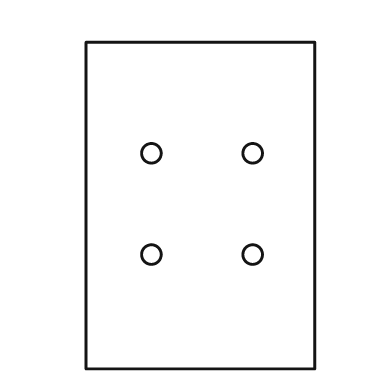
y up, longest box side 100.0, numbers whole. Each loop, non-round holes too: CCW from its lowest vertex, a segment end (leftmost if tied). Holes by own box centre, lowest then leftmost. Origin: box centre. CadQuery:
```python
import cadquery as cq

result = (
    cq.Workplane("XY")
    .moveTo(-35.0, -50.0)
    .lineTo(35.0, -50.0)
    .lineTo(35.0, 50.0)
    .lineTo(-35.0, 50.0)
    .close()
    .moveTo(-15.0, -15.0)
    .circle(3.0)
    .moveTo(16.0, -15.0)
    .circle(3.0)
    .moveTo(-15.0, 16.0)
    .circle(3.0)
    .moveTo(16.0, 16.0)
    .circle(3.0)
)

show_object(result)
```